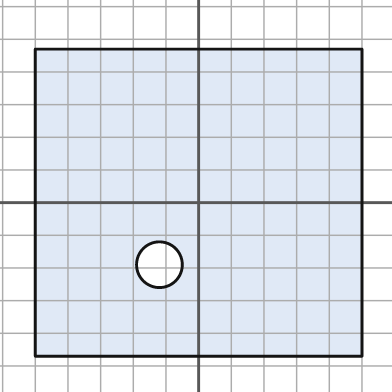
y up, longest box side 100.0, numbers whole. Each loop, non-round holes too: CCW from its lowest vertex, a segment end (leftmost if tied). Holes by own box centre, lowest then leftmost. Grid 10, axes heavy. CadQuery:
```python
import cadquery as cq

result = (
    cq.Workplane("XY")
    .moveTo(-50.0, -47.0)
    .lineTo(50.0, -47.0)
    .lineTo(50.0, 47.0)
    .lineTo(-50.0, 47.0)
    .close()
    .moveTo(-12.0, -19.0)
    .circle(7.0)
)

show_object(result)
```